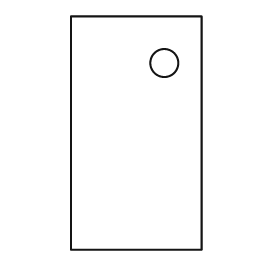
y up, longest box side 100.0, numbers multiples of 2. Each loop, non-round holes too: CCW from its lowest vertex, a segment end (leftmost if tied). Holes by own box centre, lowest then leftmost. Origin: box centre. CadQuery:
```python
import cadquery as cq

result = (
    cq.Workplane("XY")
    .moveTo(-28.0, -50.0)
    .lineTo(28.0, -50.0)
    .lineTo(28.0, 50.0)
    .lineTo(-28.0, 50.0)
    .close()
    .moveTo(12.0, 30.0)
    .circle(6.0)
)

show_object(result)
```